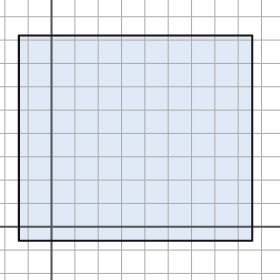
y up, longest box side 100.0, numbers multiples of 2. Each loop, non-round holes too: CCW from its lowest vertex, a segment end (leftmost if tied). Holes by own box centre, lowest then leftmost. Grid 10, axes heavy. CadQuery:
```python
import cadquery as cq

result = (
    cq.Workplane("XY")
    .moveTo(-14.0, -6.0)
    .lineTo(86.0, -6.0)
    .lineTo(86.0, 82.0)
    .lineTo(-14.0, 82.0)
    .close()
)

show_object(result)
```